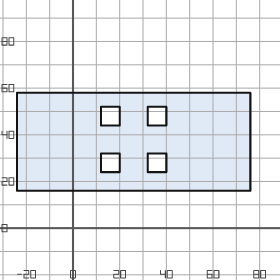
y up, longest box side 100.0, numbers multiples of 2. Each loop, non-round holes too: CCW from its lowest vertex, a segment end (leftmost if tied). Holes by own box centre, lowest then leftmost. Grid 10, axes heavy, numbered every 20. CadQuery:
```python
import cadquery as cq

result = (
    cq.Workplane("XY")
    .moveTo(-24.0, 16.0)
    .lineTo(76.0, 16.0)
    .lineTo(76.0, 58.0)
    .lineTo(-24.0, 58.0)
    .close()
    .moveTo(12.0, 24.0)
    .lineTo(20.0, 24.0)
    .lineTo(20.0, 32.0)
    .lineTo(12.0, 32.0)
    .close()
    .moveTo(32.0, 24.0)
    .lineTo(40.0, 24.0)
    .lineTo(40.0, 32.0)
    .lineTo(32.0, 32.0)
    .close()
    .moveTo(12.0, 44.0)
    .lineTo(20.0, 44.0)
    .lineTo(20.0, 52.0)
    .lineTo(12.0, 52.0)
    .close()
    .moveTo(32.0, 44.0)
    .lineTo(40.0, 44.0)
    .lineTo(40.0, 52.0)
    .lineTo(32.0, 52.0)
    .close()
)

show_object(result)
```